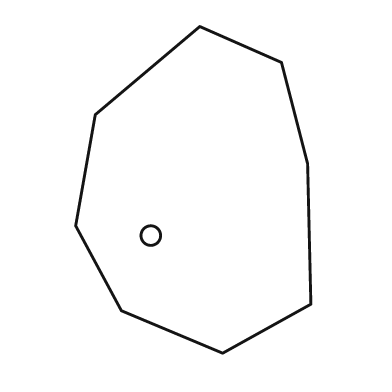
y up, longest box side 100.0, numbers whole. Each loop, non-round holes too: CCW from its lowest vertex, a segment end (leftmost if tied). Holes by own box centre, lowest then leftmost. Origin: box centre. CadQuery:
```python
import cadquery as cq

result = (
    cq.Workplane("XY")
    .moveTo(9.0, -50.0)
    .lineTo(36.0, -35.0)
    .lineTo(35.0, 8.0)
    .lineTo(27.0, 39.0)
    .lineTo(2.0, 50.0)
    .lineTo(-30.0, 23.0)
    .lineTo(-36.0, -11.0)
    .lineTo(-22.0, -37.0)
    .close()
    .moveTo(-13.0, -14.0)
    .circle(3.0)
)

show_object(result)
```